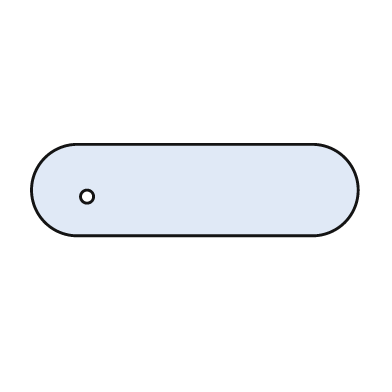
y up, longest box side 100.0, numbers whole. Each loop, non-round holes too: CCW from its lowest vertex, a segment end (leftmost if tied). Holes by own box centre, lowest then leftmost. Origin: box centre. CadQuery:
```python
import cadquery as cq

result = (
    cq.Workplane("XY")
    .moveTo(-36.0, -14.0)
    .lineTo(36.0, -14.0)
    .threePointArc((50.0, 0.0), (36.0, 14.0))
    .lineTo(-36.0, 14.0)
    .threePointArc((-50.0, 0.0), (-36.0, -14.0))
    .close()
    .moveTo(-33.0, -2.0)
    .circle(2.0)
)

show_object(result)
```